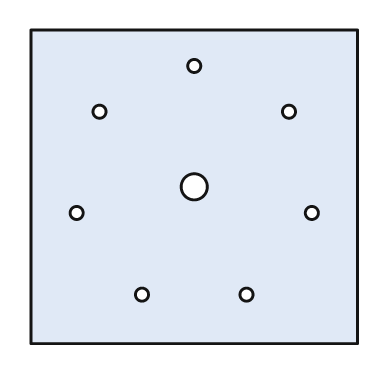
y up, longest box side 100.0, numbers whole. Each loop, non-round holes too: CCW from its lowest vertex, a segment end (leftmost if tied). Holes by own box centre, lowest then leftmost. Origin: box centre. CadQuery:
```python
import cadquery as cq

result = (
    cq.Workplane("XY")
    .moveTo(-50.0, -48.0)
    .lineTo(50.0, -48.0)
    .lineTo(50.0, 48.0)
    .lineTo(-50.0, 48.0)
    .close()
    .moveTo(-16.0, -33.0)
    .circle(2.0)
    .moveTo(16.0, -33.0)
    .circle(2.0)
    .moveTo(-36.0, -8.0)
    .circle(2.0)
    .moveTo(36.0, -8.0)
    .circle(2.0)
    .moveTo(0.0, 0.0)
    .circle(4.0)
    .moveTo(-29.0, 23.0)
    .circle(2.0)
    .moveTo(29.0, 23.0)
    .circle(2.0)
    .moveTo(0.0, 37.0)
    .circle(2.0)
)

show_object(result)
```